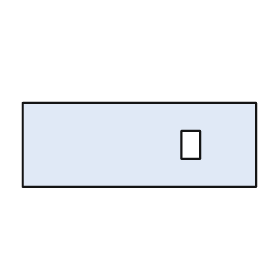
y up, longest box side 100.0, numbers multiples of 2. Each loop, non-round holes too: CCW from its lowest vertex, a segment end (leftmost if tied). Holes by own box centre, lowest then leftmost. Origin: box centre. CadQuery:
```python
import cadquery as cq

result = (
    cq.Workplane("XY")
    .moveTo(-50.0, -18.0)
    .lineTo(50.0, -18.0)
    .lineTo(50.0, 18.0)
    .lineTo(-50.0, 18.0)
    .close()
    .moveTo(18.0, -6.0)
    .lineTo(26.0, -6.0)
    .lineTo(26.0, 6.0)
    .lineTo(18.0, 6.0)
    .close()
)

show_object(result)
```